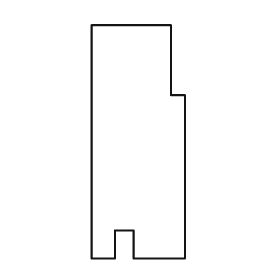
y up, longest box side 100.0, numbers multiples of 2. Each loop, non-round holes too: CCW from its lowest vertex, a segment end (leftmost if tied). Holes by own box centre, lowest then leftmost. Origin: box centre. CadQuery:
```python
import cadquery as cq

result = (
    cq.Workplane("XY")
    .moveTo(-20.0, -50.0)
    .lineTo(-10.0, -50.0)
    .lineTo(-10.0, -38.0)
    .lineTo(-2.0, -38.0)
    .lineTo(-2.0, -50.0)
    .lineTo(20.0, -50.0)
    .lineTo(20.0, 20.0)
    .lineTo(14.0, 20.0)
    .lineTo(14.0, 50.0)
    .lineTo(-20.0, 50.0)
    .close()
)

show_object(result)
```